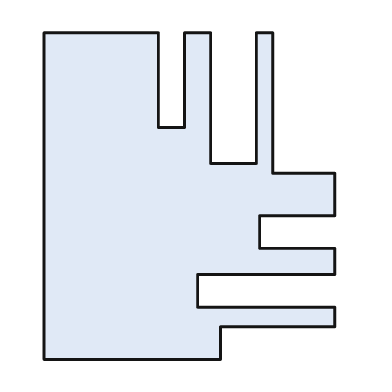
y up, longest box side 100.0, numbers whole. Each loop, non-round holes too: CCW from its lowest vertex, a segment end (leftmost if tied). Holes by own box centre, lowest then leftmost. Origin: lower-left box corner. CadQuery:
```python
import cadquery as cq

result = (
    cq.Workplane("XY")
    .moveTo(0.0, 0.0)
    .lineTo(54.0, 0.0)
    .lineTo(54.0, 10.0)
    .lineTo(89.0, 10.0)
    .lineTo(89.0, 16.0)
    .lineTo(47.0, 16.0)
    .lineTo(47.0, 26.0)
    .lineTo(89.0, 26.0)
    .lineTo(89.0, 34.0)
    .lineTo(66.0, 34.0)
    .lineTo(66.0, 44.0)
    .lineTo(89.0, 44.0)
    .lineTo(89.0, 57.0)
    .lineTo(70.0, 57.0)
    .lineTo(70.0, 100.0)
    .lineTo(65.0, 100.0)
    .lineTo(65.0, 60.0)
    .lineTo(51.0, 60.0)
    .lineTo(51.0, 100.0)
    .lineTo(43.0, 100.0)
    .lineTo(43.0, 71.0)
    .lineTo(35.0, 71.0)
    .lineTo(35.0, 100.0)
    .lineTo(0.0, 100.0)
    .close()
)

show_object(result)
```